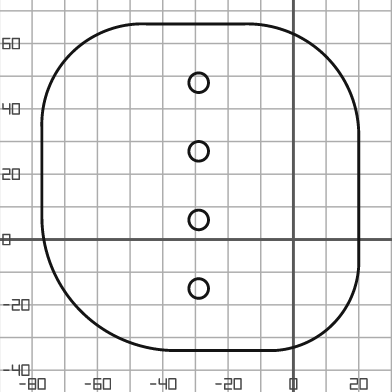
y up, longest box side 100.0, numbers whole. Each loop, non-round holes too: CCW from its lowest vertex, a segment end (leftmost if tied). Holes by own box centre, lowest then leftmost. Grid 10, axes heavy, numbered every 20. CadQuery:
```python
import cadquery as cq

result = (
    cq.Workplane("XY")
    .moveTo(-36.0, -34.0)
    .lineTo(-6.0, -34.0)
    .threePointArc((12.0, -26.0), (20.0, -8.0))
    .lineTo(20.0, 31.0)
    .threePointArc((10.0, 56.0), (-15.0, 66.0))
    .lineTo(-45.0, 66.0)
    .threePointArc((-68.0, 57.0), (-77.0, 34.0))
    .lineTo(-77.0, 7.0)
    .threePointArc((-65.0, -22.0), (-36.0, -34.0))
    .close()
    .moveTo(-29.0, -15.0)
    .circle(3.0)
    .moveTo(-29.0, 6.0)
    .circle(3.0)
    .moveTo(-29.0, 27.0)
    .circle(3.0)
    .moveTo(-29.0, 48.0)
    .circle(3.0)
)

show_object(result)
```